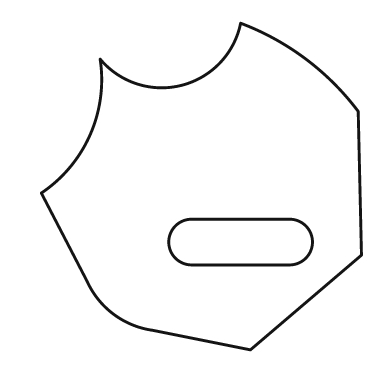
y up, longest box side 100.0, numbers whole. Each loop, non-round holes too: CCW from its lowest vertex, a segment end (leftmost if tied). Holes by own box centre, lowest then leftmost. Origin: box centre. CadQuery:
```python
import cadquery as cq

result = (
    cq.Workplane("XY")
    .moveTo(15.0, -50.0)
    .lineTo(49.0, -21.0)
    .lineTo(48.0, 23.0)
    .threePointArc((32.0, 39.0), (12.0, 50.0))
    .threePointArc((-6.0, 31.0), (-31.0, 39.0))
    .threePointArc((-34.0, 16.0), (-49.0, -2.0))
    .lineTo(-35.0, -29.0)
    .threePointArc((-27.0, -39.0), (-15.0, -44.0))
    .close()
    .moveTo(-3.0, -24.0)
    .lineTo(27.0, -24.0)
    .threePointArc((34.0, -17.0), (27.0, -10.0))
    .lineTo(-3.0, -10.0)
    .threePointArc((-10.0, -17.0), (-3.0, -24.0))
    .close()
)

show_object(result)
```